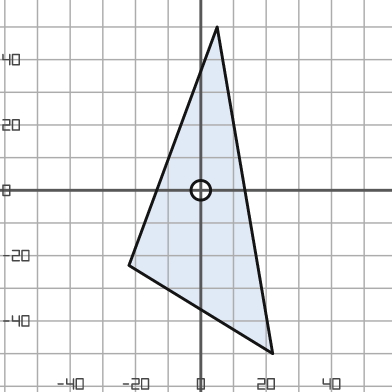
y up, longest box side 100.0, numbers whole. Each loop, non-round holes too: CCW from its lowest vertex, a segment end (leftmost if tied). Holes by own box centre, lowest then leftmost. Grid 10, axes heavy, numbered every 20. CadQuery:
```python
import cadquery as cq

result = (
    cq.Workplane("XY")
    .moveTo(22.0, -50.0)
    .lineTo(5.0, 50.0)
    .lineTo(-22.0, -23.0)
    .close()
    .moveTo(0.0, 0.0)
    .circle(3.0)
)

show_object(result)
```